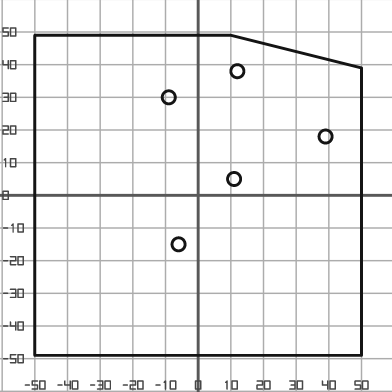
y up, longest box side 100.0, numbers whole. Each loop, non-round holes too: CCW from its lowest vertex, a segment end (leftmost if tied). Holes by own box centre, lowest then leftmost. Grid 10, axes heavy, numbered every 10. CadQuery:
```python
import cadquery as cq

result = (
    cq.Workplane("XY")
    .moveTo(-50.0, -49.0)
    .lineTo(50.0, -49.0)
    .lineTo(50.0, 39.0)
    .lineTo(10.0, 49.0)
    .lineTo(-50.0, 49.0)
    .close()
    .moveTo(-6.0, -15.0)
    .circle(2.0)
    .moveTo(11.0, 5.0)
    .circle(2.0)
    .moveTo(39.0, 18.0)
    .circle(2.0)
    .moveTo(-9.0, 30.0)
    .circle(2.0)
    .moveTo(12.0, 38.0)
    .circle(2.0)
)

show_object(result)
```